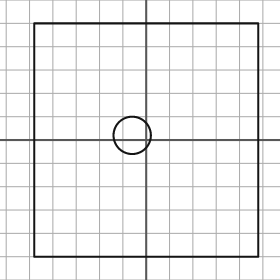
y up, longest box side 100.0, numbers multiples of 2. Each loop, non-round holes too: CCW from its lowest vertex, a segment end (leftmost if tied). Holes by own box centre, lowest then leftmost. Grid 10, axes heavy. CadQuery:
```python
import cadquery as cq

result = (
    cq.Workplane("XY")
    .moveTo(-48.0, -50.0)
    .lineTo(48.0, -50.0)
    .lineTo(48.0, 50.0)
    .lineTo(-48.0, 50.0)
    .close()
    .moveTo(-6.0, 2.0)
    .circle(8.0)
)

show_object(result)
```